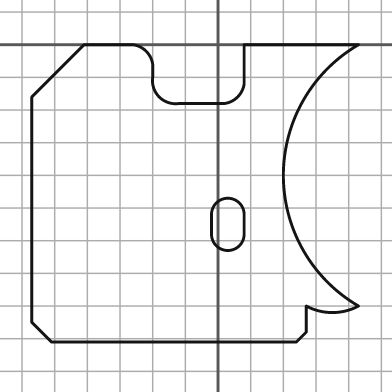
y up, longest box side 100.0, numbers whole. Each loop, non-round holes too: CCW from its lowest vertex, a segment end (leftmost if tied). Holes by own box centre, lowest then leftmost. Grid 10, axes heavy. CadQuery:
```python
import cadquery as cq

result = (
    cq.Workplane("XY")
    .moveTo(-51.0, -91.0)
    .lineTo(24.0, -91.0)
    .lineTo(27.0, -88.0)
    .lineTo(27.0, -80.0)
    .threePointArc((35.0, -82.0), (43.0, -80.0))
    .threePointArc((20.0, -40.0), (43.0, 0.0))
    .lineTo(8.0, 0.0)
    .lineTo(8.0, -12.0)
    .threePointArc((6.0, -16.0), (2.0, -18.0))
    .lineTo(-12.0, -18.0)
    .threePointArc((-18.0, -16.0), (-20.0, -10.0))
    .lineTo(-20.0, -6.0)
    .threePointArc((-22.0, -2.0), (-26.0, 0.0))
    .lineTo(-41.0, 0.0)
    .lineTo(-57.0, -16.0)
    .lineTo(-57.0, -85.0)
    .close()
    .moveTo(-2.0, -58.0)
    .threePointArc((3.0, -63.0), (8.0, -58.0))
    .lineTo(8.0, -52.0)
    .threePointArc((3.0, -47.0), (-2.0, -52.0))
    .close()
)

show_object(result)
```